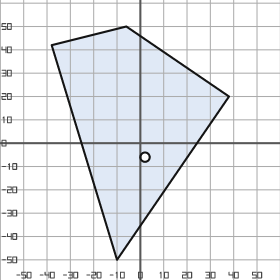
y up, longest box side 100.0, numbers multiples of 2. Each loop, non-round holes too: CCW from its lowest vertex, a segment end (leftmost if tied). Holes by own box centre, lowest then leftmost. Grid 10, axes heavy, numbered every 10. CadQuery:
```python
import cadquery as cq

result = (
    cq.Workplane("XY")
    .moveTo(-10.0, -50.0)
    .lineTo(38.0, 20.0)
    .lineTo(-6.0, 50.0)
    .lineTo(-38.0, 42.0)
    .close()
    .moveTo(2.0, -6.0)
    .circle(2.0)
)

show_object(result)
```